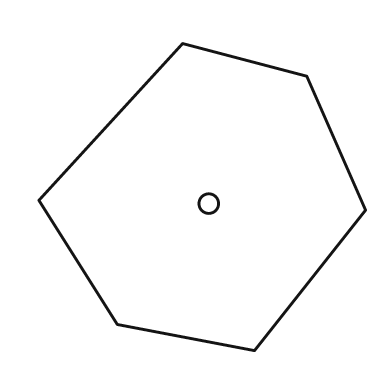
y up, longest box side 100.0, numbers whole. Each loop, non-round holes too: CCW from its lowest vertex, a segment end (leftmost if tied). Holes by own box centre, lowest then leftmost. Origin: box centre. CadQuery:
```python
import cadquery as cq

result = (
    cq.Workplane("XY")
    .moveTo(16.0, -47.0)
    .lineTo(50.0, -4.0)
    .lineTo(32.0, 37.0)
    .lineTo(-6.0, 47.0)
    .lineTo(-50.0, -1.0)
    .lineTo(-26.0, -39.0)
    .close()
    .moveTo(2.0, -2.0)
    .circle(3.0)
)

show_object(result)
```